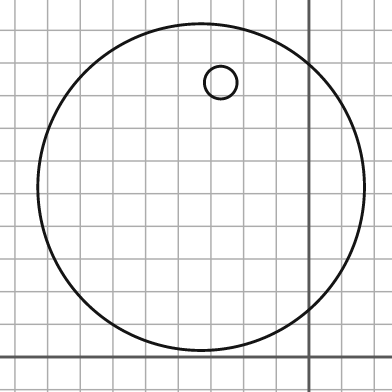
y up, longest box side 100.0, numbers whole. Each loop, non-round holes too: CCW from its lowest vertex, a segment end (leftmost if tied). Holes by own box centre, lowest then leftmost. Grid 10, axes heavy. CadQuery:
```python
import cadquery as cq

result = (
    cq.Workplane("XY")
    .moveTo(-33.0, 52.0)
    .circle(50.0)
    .moveTo(-27.0, 84.0)
    .circle(5.0)
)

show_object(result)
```